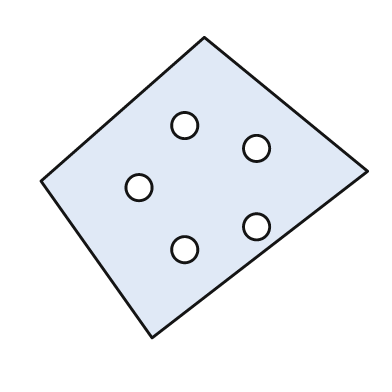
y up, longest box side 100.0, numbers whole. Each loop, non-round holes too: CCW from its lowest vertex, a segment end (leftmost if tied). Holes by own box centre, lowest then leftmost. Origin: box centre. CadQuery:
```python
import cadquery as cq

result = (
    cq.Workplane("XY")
    .moveTo(-16.0, -46.0)
    .lineTo(50.0, 5.0)
    .lineTo(0.0, 46.0)
    .lineTo(-50.0, 2.0)
    .close()
    .moveTo(-6.0, -19.0)
    .circle(4.0)
    .moveTo(16.0, -12.0)
    .circle(4.0)
    .moveTo(-20.0, 0.0)
    .circle(4.0)
    .moveTo(16.0, 12.0)
    .circle(4.0)
    .moveTo(-6.0, 19.0)
    .circle(4.0)
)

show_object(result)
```